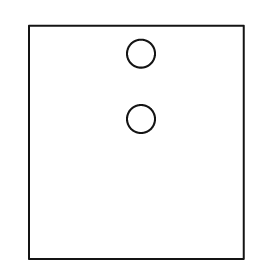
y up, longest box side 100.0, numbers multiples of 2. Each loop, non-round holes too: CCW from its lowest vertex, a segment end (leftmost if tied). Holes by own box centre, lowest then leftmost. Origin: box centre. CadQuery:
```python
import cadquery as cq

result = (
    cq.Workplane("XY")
    .moveTo(-46.0, -50.0)
    .lineTo(46.0, -50.0)
    .lineTo(46.0, 50.0)
    .lineTo(-46.0, 50.0)
    .close()
    .moveTo(2.0, 10.0)
    .circle(6.0)
    .moveTo(2.0, 38.0)
    .circle(6.0)
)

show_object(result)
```